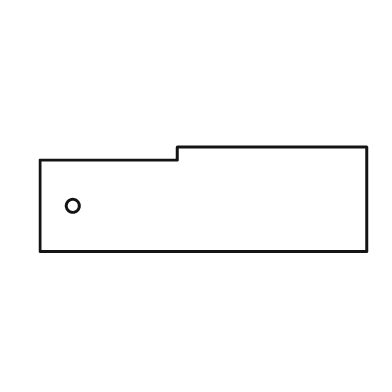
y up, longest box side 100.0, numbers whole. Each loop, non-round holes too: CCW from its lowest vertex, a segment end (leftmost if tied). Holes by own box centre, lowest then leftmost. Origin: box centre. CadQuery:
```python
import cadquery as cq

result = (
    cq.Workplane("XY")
    .moveTo(-50.0, -16.0)
    .lineTo(50.0, -16.0)
    .lineTo(50.0, 16.0)
    .lineTo(-8.0, 16.0)
    .lineTo(-8.0, 12.0)
    .lineTo(-50.0, 12.0)
    .close()
    .moveTo(-40.0, -2.0)
    .circle(2.0)
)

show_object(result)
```